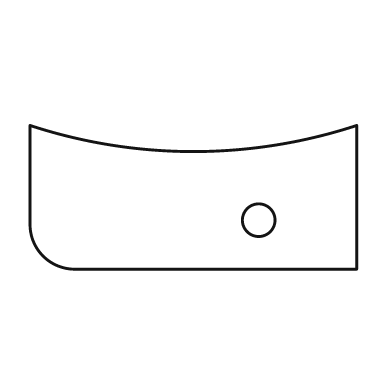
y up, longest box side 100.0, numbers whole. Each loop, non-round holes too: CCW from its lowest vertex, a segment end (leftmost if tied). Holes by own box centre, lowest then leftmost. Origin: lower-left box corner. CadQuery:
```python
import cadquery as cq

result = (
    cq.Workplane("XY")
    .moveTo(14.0, 0.0)
    .lineTo(100.0, 0.0)
    .lineTo(100.0, 44.0)
    .threePointArc((50.0, 36.0), (0.0, 44.0))
    .lineTo(0.0, 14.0)
    .threePointArc((4.0, 4.0), (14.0, 0.0))
    .close()
    .moveTo(70.0, 15.0)
    .circle(5.0)
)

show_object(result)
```